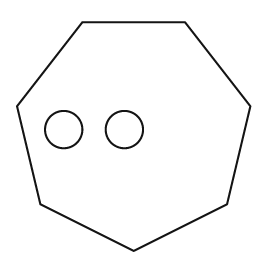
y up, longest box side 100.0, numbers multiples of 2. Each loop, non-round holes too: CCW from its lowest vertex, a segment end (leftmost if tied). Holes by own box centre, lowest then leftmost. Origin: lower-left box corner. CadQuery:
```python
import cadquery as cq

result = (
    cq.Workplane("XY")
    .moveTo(50.0, 0.0)
    .lineTo(90.0, 20.0)
    .lineTo(100.0, 62.0)
    .lineTo(72.0, 98.0)
    .lineTo(28.0, 98.0)
    .lineTo(0.0, 62.0)
    .lineTo(10.0, 20.0)
    .close()
    .moveTo(20.0, 52.0)
    .circle(8.0)
    .moveTo(46.0, 52.0)
    .circle(8.0)
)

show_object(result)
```